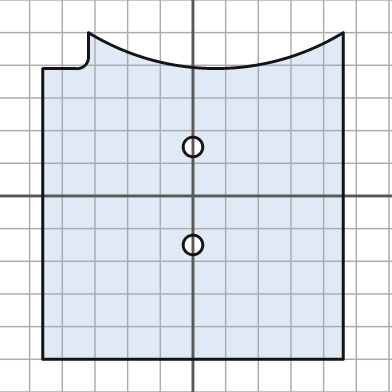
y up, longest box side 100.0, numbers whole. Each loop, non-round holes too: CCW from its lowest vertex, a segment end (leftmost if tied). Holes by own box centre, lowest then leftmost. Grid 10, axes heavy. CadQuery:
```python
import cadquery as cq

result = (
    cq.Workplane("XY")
    .moveTo(-46.0, -50.0)
    .lineTo(46.0, -50.0)
    .lineTo(46.0, 50.0)
    .threePointArc((7.0, 39.0), (-32.0, 50.0))
    .lineTo(-32.0, 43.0)
    .threePointArc((-33.0, 40.0), (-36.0, 39.0))
    .lineTo(-46.0, 39.0)
    .close()
    .moveTo(0.0, -15.0)
    .circle(3.0)
    .moveTo(0.0, 15.0)
    .circle(3.0)
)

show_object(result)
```